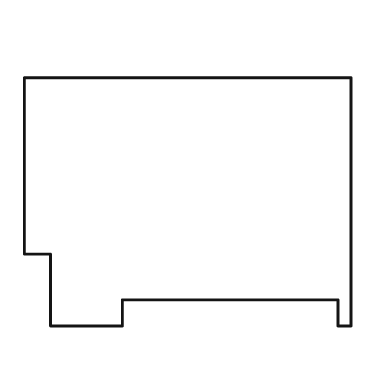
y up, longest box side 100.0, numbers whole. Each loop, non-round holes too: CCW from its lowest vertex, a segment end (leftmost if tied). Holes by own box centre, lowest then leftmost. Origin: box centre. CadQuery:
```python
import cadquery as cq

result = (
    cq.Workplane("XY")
    .moveTo(-42.0, -38.0)
    .lineTo(-20.0, -38.0)
    .lineTo(-20.0, -30.0)
    .lineTo(46.0, -30.0)
    .lineTo(46.0, -38.0)
    .lineTo(50.0, -38.0)
    .lineTo(50.0, 38.0)
    .lineTo(-50.0, 38.0)
    .lineTo(-50.0, -16.0)
    .lineTo(-42.0, -16.0)
    .close()
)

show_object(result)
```